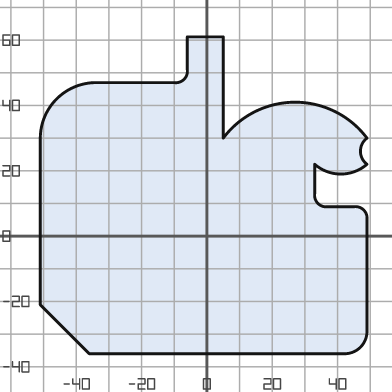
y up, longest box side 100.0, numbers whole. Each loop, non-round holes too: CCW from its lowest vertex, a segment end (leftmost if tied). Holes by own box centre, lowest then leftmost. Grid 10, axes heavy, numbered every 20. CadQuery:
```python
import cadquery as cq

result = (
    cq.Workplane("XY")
    .moveTo(-36.0, -36.0)
    .lineTo(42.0, -36.0)
    .threePointArc((47.0, -34.0), (49.0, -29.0))
    .lineTo(49.0, 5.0)
    .threePointArc((48.0, 8.0), (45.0, 9.0))
    .lineTo(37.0, 9.0)
    .threePointArc((34.0, 10.0), (33.0, 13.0))
    .lineTo(33.0, 22.0)
    .threePointArc((41.0, 19.0), (49.0, 22.0))
    .threePointArc((47.0, 26.0), (49.0, 30.0))
    .threePointArc((27.0, 41.0), (5.0, 30.0))
    .lineTo(5.0, 61.0)
    .lineTo(-6.0, 61.0)
    .lineTo(-6.0, 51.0)
    .threePointArc((-7.0, 48.0), (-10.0, 47.0))
    .lineTo(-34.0, 47.0)
    .threePointArc((-46.0, 42.0), (-51.0, 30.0))
    .lineTo(-51.0, -21.0)
    .close()
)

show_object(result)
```